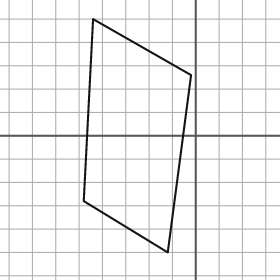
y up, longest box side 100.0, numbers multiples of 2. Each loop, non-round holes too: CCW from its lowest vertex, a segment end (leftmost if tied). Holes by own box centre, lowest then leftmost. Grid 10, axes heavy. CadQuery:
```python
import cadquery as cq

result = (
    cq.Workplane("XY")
    .moveTo(-12.0, -50.0)
    .lineTo(-2.0, 26.0)
    .lineTo(-44.0, 50.0)
    .lineTo(-48.0, -28.0)
    .close()
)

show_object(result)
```